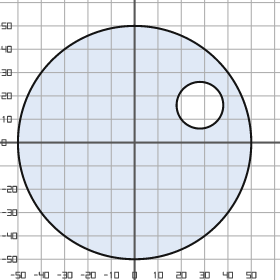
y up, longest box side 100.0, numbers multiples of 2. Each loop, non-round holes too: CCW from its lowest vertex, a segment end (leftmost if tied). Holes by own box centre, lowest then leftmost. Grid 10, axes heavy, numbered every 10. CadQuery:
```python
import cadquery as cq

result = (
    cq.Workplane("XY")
    .moveTo(0.0, 0.0)
    .circle(50.0)
    .moveTo(28.0, 16.0)
    .circle(10.0)
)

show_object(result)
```